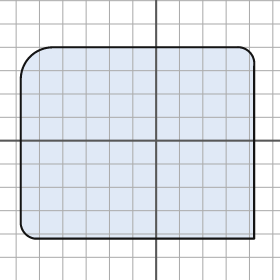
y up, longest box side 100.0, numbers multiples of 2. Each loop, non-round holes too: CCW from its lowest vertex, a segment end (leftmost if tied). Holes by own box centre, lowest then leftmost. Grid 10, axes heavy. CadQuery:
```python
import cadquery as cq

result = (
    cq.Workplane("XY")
    .moveTo(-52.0, -42.0)
    .lineTo(42.0, -42.0)
    .lineTo(42.0, 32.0)
    .threePointArc((40.0, 38.0), (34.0, 40.0))
    .lineTo(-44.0, 40.0)
    .threePointArc((-54.0, 36.0), (-58.0, 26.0))
    .lineTo(-58.0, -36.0)
    .threePointArc((-56.0, -40.0), (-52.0, -42.0))
    .close()
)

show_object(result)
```